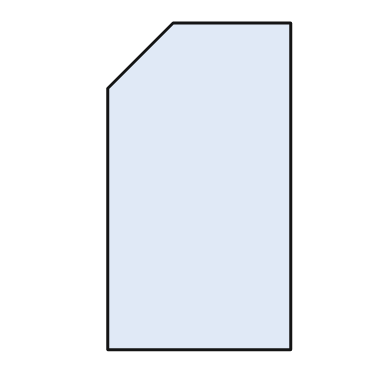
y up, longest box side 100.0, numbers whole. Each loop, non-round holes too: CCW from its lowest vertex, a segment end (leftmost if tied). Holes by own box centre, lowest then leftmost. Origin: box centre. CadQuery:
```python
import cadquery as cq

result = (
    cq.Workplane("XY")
    .moveTo(-28.0, -50.0)
    .lineTo(28.0, -50.0)
    .lineTo(28.0, 50.0)
    .lineTo(-8.0, 50.0)
    .lineTo(-28.0, 30.0)
    .close()
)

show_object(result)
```